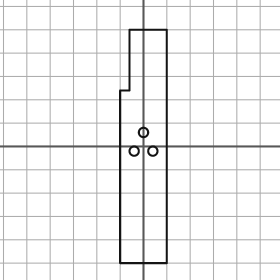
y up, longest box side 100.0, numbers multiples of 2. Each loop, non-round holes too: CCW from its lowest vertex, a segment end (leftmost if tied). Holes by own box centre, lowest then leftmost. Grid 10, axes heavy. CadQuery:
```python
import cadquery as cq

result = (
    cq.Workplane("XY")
    .moveTo(-10.0, -50.0)
    .lineTo(10.0, -50.0)
    .lineTo(10.0, 50.0)
    .lineTo(-6.0, 50.0)
    .lineTo(-6.0, 24.0)
    .lineTo(-10.0, 24.0)
    .close()
    .moveTo(-4.0, -2.0)
    .circle(2.0)
    .moveTo(4.0, -2.0)
    .circle(2.0)
    .moveTo(0.0, 6.0)
    .circle(2.0)
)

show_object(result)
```